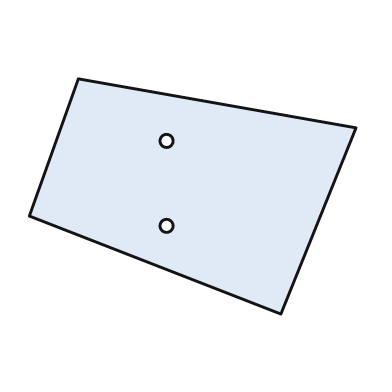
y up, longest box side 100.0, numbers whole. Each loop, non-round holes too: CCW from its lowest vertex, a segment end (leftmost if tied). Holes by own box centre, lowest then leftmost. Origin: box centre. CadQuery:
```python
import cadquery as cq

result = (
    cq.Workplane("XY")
    .moveTo(27.0, -36.0)
    .lineTo(50.0, 21.0)
    .lineTo(-35.0, 36.0)
    .lineTo(-50.0, -6.0)
    .close()
    .moveTo(-8.0, -9.0)
    .circle(2.0)
    .moveTo(-8.0, 17.0)
    .circle(2.0)
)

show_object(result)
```